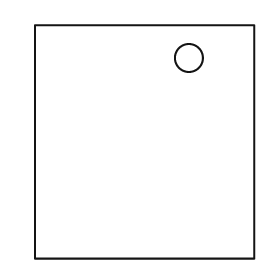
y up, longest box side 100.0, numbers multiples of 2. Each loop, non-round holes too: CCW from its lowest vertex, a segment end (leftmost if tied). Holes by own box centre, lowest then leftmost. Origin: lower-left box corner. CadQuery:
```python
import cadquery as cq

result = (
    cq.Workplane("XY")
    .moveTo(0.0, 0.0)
    .lineTo(94.0, 0.0)
    .lineTo(94.0, 100.0)
    .lineTo(0.0, 100.0)
    .close()
    .moveTo(66.0, 86.0)
    .circle(6.0)
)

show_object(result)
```